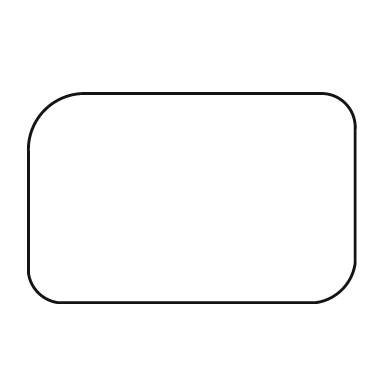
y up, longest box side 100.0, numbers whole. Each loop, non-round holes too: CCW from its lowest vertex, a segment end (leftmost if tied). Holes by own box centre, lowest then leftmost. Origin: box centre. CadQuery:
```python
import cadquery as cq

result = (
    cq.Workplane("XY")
    .moveTo(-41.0, -32.0)
    .lineTo(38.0, -32.0)
    .threePointArc((46.0, -28.0), (50.0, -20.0))
    .lineTo(50.0, 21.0)
    .threePointArc((47.0, 29.0), (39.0, 32.0))
    .lineTo(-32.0, 32.0)
    .threePointArc((-45.0, 27.0), (-50.0, 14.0))
    .lineTo(-50.0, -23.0)
    .threePointArc((-47.0, -29.0), (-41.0, -32.0))
    .close()
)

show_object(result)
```